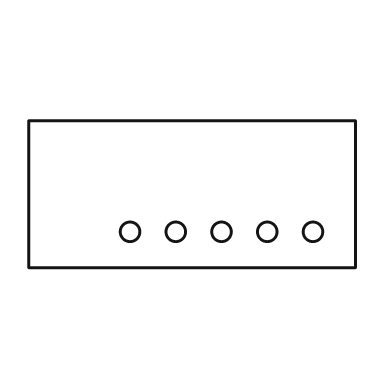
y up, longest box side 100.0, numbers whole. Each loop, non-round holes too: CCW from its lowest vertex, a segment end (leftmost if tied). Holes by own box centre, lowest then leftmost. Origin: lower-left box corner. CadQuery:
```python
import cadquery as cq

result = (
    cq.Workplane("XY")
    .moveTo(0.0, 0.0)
    .lineTo(100.0, 0.0)
    .lineTo(100.0, 45.0)
    .lineTo(0.0, 45.0)
    .close()
    .moveTo(31.0, 11.0)
    .circle(3.0)
    .moveTo(45.0, 11.0)
    .circle(3.0)
    .moveTo(59.0, 11.0)
    .circle(3.0)
    .moveTo(73.0, 11.0)
    .circle(3.0)
    .moveTo(87.0, 11.0)
    .circle(3.0)
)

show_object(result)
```